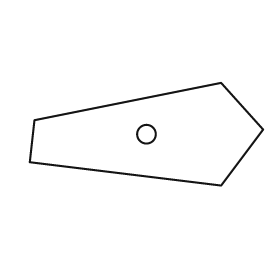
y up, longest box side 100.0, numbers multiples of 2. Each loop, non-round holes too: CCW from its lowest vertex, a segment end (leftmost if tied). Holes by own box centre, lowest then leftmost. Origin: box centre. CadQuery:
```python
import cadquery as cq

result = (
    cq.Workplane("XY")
    .moveTo(32.0, -22.0)
    .lineTo(50.0, 2.0)
    .lineTo(32.0, 22.0)
    .lineTo(-48.0, 6.0)
    .lineTo(-50.0, -12.0)
    .close()
    .moveTo(0.0, 0.0)
    .circle(4.0)
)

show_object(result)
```